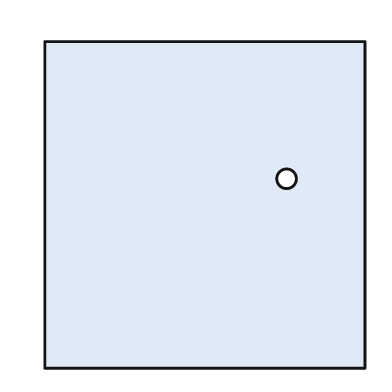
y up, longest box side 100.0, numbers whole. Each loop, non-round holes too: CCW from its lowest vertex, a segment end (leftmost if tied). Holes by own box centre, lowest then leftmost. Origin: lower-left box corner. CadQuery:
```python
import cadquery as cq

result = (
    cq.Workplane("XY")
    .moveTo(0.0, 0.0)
    .lineTo(98.0, 0.0)
    .lineTo(98.0, 100.0)
    .lineTo(0.0, 100.0)
    .close()
    .moveTo(74.0, 58.0)
    .circle(3.0)
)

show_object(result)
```